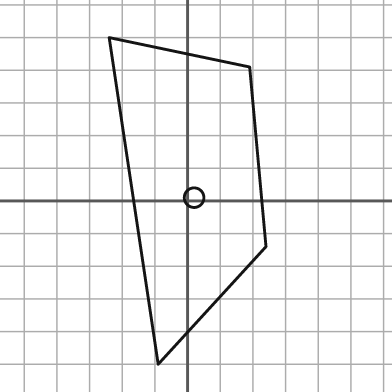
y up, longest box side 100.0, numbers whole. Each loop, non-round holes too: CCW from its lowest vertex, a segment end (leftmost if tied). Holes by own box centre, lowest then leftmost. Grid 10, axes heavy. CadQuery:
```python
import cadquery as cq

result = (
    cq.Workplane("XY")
    .moveTo(-9.0, -50.0)
    .lineTo(24.0, -14.0)
    .lineTo(19.0, 41.0)
    .lineTo(-24.0, 50.0)
    .close()
    .moveTo(2.0, 1.0)
    .circle(3.0)
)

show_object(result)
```